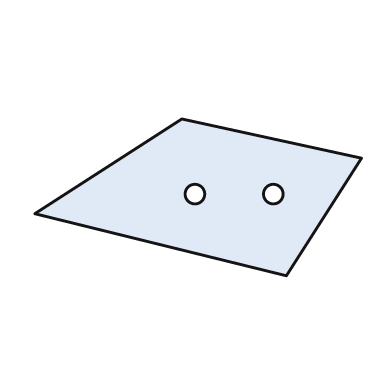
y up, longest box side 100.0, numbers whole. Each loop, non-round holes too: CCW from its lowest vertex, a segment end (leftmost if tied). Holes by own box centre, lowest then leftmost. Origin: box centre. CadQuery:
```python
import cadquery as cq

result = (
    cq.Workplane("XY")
    .moveTo(27.0, -24.0)
    .lineTo(50.0, 12.0)
    .lineTo(-5.0, 24.0)
    .lineTo(-50.0, -5.0)
    .close()
    .moveTo(-1.0, 1.0)
    .circle(3.0)
    .moveTo(23.0, 1.0)
    .circle(3.0)
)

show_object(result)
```